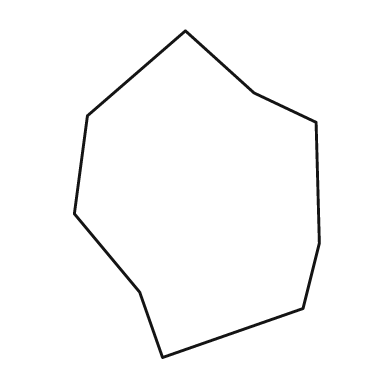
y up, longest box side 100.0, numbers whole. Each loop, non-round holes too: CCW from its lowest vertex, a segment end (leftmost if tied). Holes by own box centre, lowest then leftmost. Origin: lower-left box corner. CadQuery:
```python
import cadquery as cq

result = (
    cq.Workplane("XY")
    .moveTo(27.0, 0.0)
    .lineTo(70.0, 15.0)
    .lineTo(75.0, 35.0)
    .lineTo(74.0, 72.0)
    .lineTo(55.0, 81.0)
    .lineTo(34.0, 100.0)
    .lineTo(4.0, 74.0)
    .lineTo(0.0, 44.0)
    .lineTo(20.0, 20.0)
    .close()
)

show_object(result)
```